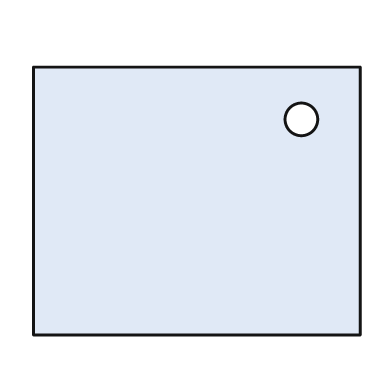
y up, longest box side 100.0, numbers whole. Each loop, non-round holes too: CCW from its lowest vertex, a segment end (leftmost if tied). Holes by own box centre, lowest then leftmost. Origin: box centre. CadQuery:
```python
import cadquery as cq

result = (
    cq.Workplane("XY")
    .moveTo(-50.0, -41.0)
    .lineTo(50.0, -41.0)
    .lineTo(50.0, 41.0)
    .lineTo(-50.0, 41.0)
    .close()
    .moveTo(32.0, 25.0)
    .circle(5.0)
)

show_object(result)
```